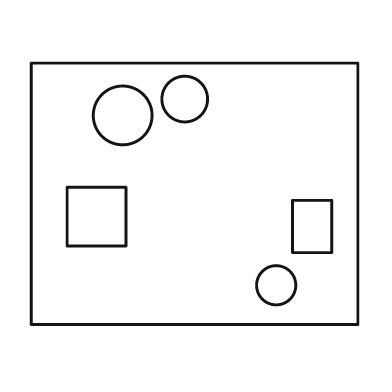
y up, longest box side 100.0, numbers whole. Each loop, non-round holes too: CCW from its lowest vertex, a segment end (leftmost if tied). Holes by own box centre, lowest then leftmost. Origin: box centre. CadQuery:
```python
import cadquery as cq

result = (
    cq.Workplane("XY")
    .moveTo(-50.0, -40.0)
    .lineTo(50.0, -40.0)
    .lineTo(50.0, 40.0)
    .lineTo(-50.0, 40.0)
    .close()
    .moveTo(25.0, -28.0)
    .circle(6.0)
    .moveTo(30.0, -18.0)
    .lineTo(42.0, -18.0)
    .lineTo(42.0, -2.0)
    .lineTo(30.0, -2.0)
    .close()
    .moveTo(-39.0, -16.0)
    .lineTo(-21.0, -16.0)
    .lineTo(-21.0, 2.0)
    .lineTo(-39.0, 2.0)
    .close()
    .moveTo(-22.0, 24.0)
    .circle(9.0)
    .moveTo(-3.0, 29.0)
    .circle(7.0)
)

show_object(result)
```